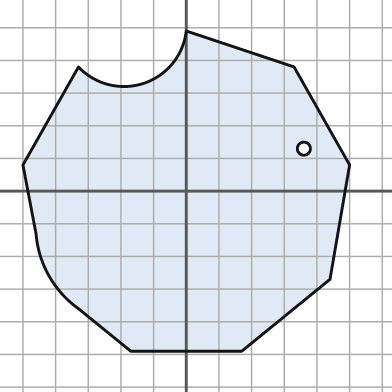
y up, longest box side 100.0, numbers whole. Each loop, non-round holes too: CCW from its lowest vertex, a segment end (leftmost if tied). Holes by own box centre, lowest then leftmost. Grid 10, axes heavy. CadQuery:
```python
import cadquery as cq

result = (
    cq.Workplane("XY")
    .moveTo(-17.0, -49.0)
    .lineTo(17.0, -49.0)
    .lineTo(44.0, -27.0)
    .lineTo(50.0, 8.0)
    .lineTo(33.0, 38.0)
    .lineTo(0.0, 49.0)
    .threePointArc((-13.0, 33.0), (-33.0, 38.0))
    .lineTo(-50.0, 8.0)
    .lineTo(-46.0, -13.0)
    .threePointArc((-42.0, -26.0), (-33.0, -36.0))
    .close()
    .moveTo(36.0, 13.0)
    .circle(2.0)
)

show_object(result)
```